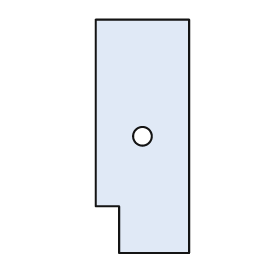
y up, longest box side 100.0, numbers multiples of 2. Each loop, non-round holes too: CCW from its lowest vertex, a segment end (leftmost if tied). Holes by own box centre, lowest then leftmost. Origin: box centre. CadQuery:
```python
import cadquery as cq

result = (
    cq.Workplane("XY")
    .moveTo(-10.0, -50.0)
    .lineTo(20.0, -50.0)
    .lineTo(20.0, 50.0)
    .lineTo(-20.0, 50.0)
    .lineTo(-20.0, -30.0)
    .lineTo(-10.0, -30.0)
    .close()
    .moveTo(0.0, 0.0)
    .circle(4.0)
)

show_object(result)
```